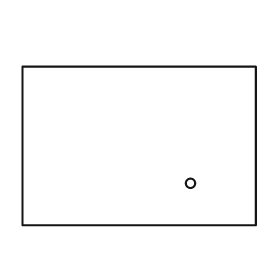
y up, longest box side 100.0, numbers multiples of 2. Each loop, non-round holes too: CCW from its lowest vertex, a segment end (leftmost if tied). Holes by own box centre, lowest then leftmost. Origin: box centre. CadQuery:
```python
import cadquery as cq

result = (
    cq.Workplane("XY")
    .moveTo(-50.0, -34.0)
    .lineTo(50.0, -34.0)
    .lineTo(50.0, 34.0)
    .lineTo(-50.0, 34.0)
    .close()
    .moveTo(22.0, -16.0)
    .circle(2.0)
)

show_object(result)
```